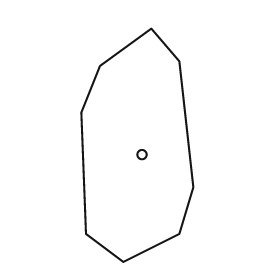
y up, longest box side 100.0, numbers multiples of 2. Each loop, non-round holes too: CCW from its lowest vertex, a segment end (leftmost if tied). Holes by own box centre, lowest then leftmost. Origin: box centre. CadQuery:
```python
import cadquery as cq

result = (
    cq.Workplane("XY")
    .moveTo(-6.0, -50.0)
    .lineTo(18.0, -38.0)
    .lineTo(24.0, -18.0)
    .lineTo(18.0, 36.0)
    .lineTo(6.0, 50.0)
    .lineTo(-16.0, 34.0)
    .lineTo(-24.0, 14.0)
    .lineTo(-22.0, -38.0)
    .close()
    .moveTo(2.0, -4.0)
    .circle(2.0)
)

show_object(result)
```